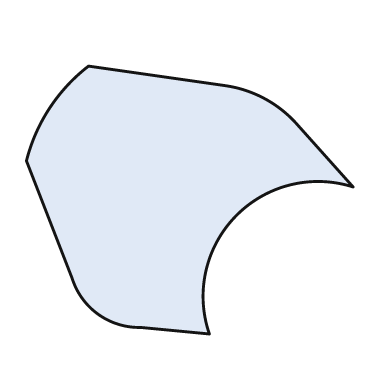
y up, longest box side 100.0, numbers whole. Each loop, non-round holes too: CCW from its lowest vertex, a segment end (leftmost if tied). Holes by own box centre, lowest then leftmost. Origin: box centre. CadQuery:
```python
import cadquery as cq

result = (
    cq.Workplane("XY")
    .moveTo(6.0, -41.0)
    .threePointArc((14.0, -5.0), (50.0, 4.0))
    .lineTo(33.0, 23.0)
    .threePointArc((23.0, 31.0), (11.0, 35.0))
    .lineTo(-31.0, 41.0)
    .threePointArc((-43.0, 28.0), (-50.0, 12.0))
    .lineTo(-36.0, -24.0)
    .threePointArc((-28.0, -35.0), (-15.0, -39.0))
    .close()
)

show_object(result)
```